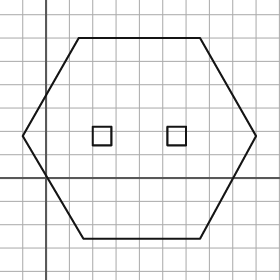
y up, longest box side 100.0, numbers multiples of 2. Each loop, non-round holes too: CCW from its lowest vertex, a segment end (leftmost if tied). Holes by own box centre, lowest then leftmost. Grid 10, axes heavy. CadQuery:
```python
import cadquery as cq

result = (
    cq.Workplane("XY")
    .moveTo(16.0, -26.0)
    .lineTo(66.0, -26.0)
    .lineTo(90.0, 18.0)
    .lineTo(66.0, 60.0)
    .lineTo(14.0, 60.0)
    .lineTo(-10.0, 18.0)
    .close()
    .moveTo(20.0, 14.0)
    .lineTo(28.0, 14.0)
    .lineTo(28.0, 22.0)
    .lineTo(20.0, 22.0)
    .close()
    .moveTo(52.0, 14.0)
    .lineTo(60.0, 14.0)
    .lineTo(60.0, 22.0)
    .lineTo(52.0, 22.0)
    .close()
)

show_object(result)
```